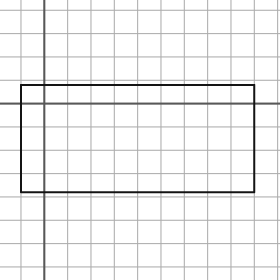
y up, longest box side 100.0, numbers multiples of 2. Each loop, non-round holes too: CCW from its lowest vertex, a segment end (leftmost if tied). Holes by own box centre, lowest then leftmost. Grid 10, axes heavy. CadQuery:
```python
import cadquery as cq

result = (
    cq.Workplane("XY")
    .moveTo(-10.0, -38.0)
    .lineTo(90.0, -38.0)
    .lineTo(90.0, 8.0)
    .lineTo(-10.0, 8.0)
    .close()
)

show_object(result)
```